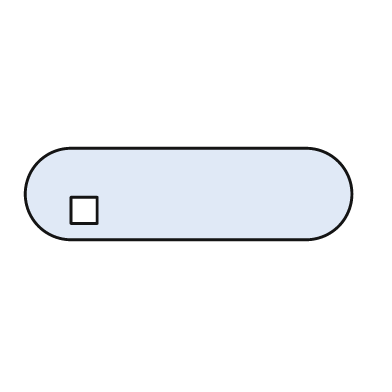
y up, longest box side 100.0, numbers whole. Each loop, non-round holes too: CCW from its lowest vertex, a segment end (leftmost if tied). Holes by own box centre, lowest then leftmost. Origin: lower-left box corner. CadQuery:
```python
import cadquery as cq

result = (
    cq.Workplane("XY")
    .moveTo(14.0, 0.0)
    .lineTo(86.0, 0.0)
    .threePointArc((100.0, 14.0), (86.0, 28.0))
    .lineTo(14.0, 28.0)
    .threePointArc((0.0, 14.0), (14.0, 0.0))
    .close()
    .moveTo(14.0, 5.0)
    .lineTo(22.0, 5.0)
    .lineTo(22.0, 13.0)
    .lineTo(14.0, 13.0)
    .close()
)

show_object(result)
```